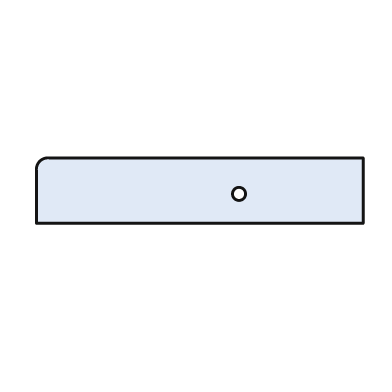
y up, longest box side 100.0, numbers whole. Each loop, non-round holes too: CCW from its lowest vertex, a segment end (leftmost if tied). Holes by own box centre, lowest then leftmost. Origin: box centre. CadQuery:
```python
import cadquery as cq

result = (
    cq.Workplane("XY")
    .moveTo(-50.0, -10.0)
    .lineTo(50.0, -10.0)
    .lineTo(50.0, 10.0)
    .lineTo(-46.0, 10.0)
    .threePointArc((-49.0, 9.0), (-50.0, 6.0))
    .close()
    .moveTo(12.0, -1.0)
    .circle(2.0)
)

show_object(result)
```